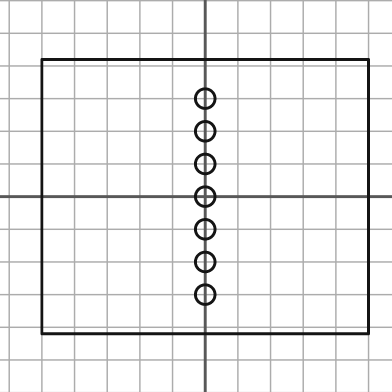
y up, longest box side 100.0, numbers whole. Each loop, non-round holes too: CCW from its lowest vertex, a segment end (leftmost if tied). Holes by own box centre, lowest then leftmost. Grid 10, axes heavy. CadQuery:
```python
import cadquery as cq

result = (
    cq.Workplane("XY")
    .moveTo(-50.0, -42.0)
    .lineTo(50.0, -42.0)
    .lineTo(50.0, 42.0)
    .lineTo(-50.0, 42.0)
    .close()
    .moveTo(0.0, -30.0)
    .circle(3.0)
    .moveTo(0.0, -20.0)
    .circle(3.0)
    .moveTo(0.0, -10.0)
    .circle(3.0)
    .moveTo(0.0, 0.0)
    .circle(3.0)
    .moveTo(0.0, 10.0)
    .circle(3.0)
    .moveTo(0.0, 20.0)
    .circle(3.0)
    .moveTo(0.0, 30.0)
    .circle(3.0)
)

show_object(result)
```